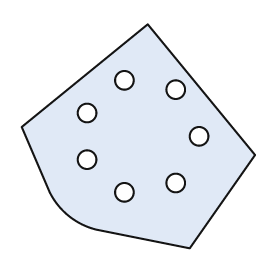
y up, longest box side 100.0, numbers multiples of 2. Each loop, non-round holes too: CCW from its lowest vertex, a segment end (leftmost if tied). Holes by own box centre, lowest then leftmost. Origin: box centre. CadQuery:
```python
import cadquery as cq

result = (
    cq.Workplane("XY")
    .moveTo(22.0, -48.0)
    .lineTo(50.0, -8.0)
    .lineTo(4.0, 48.0)
    .lineTo(-50.0, 4.0)
    .lineTo(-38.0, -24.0)
    .threePointArc((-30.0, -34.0), (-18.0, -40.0))
    .close()
    .moveTo(-6.0, -24.0)
    .circle(4.0)
    .moveTo(16.0, -20.0)
    .circle(4.0)
    .moveTo(-22.0, -10.0)
    .circle(4.0)
    .moveTo(26.0, 0.0)
    .circle(4.0)
    .moveTo(-22.0, 10.0)
    .circle(4.0)
    .moveTo(16.0, 20.0)
    .circle(4.0)
    .moveTo(-6.0, 24.0)
    .circle(4.0)
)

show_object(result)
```